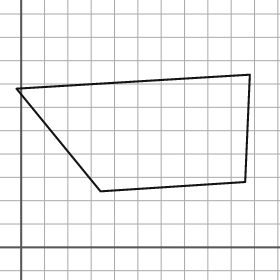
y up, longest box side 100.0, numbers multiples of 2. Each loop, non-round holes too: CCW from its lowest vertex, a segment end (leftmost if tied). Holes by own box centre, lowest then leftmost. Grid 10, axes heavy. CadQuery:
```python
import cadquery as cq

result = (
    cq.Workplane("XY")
    .moveTo(34.0, 24.0)
    .lineTo(96.0, 28.0)
    .lineTo(98.0, 74.0)
    .lineTo(-2.0, 68.0)
    .close()
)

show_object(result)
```